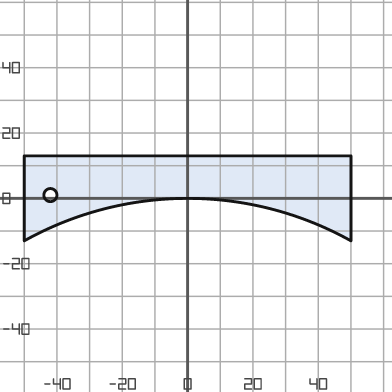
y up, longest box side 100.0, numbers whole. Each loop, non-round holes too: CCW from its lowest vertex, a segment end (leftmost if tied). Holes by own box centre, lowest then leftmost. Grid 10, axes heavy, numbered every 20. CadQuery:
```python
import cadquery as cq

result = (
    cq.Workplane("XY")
    .moveTo(-50.0, -13.0)
    .threePointArc((0.0, 0.0), (50.0, -13.0))
    .lineTo(50.0, 13.0)
    .lineTo(-50.0, 13.0)
    .close()
    .moveTo(-42.0, 1.0)
    .circle(2.0)
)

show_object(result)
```